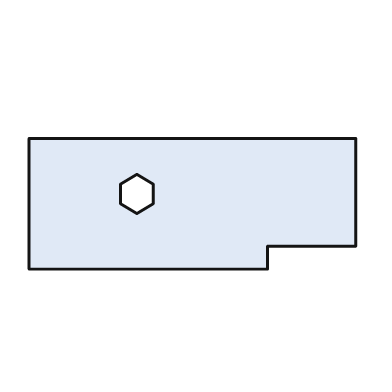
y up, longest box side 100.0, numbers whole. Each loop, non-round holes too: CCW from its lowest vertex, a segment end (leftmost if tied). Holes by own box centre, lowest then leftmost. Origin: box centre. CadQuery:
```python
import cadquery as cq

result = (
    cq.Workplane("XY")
    .moveTo(-50.0, -20.0)
    .lineTo(23.0, -20.0)
    .lineTo(23.0, -13.0)
    .lineTo(50.0, -13.0)
    .lineTo(50.0, 20.0)
    .lineTo(-50.0, 20.0)
    .close()
    .moveTo(-17.0, -3.0)
    .lineTo(-12.0, 0.0)
    .lineTo(-12.0, 6.0)
    .lineTo(-17.0, 9.0)
    .lineTo(-22.0, 6.0)
    .lineTo(-22.0, 0.0)
    .close()
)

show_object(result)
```